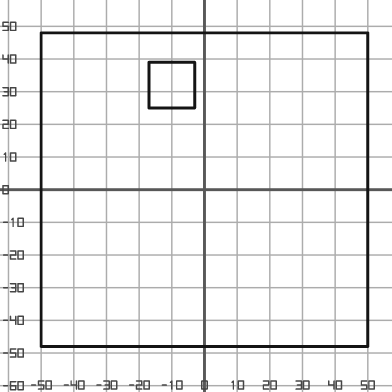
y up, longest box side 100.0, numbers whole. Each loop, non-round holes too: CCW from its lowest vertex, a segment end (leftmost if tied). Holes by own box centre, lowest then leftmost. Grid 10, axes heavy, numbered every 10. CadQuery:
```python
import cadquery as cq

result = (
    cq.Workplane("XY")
    .moveTo(-50.0, -48.0)
    .lineTo(50.0, -48.0)
    .lineTo(50.0, 48.0)
    .lineTo(-50.0, 48.0)
    .close()
    .moveTo(-17.0, 25.0)
    .lineTo(-3.0, 25.0)
    .lineTo(-3.0, 39.0)
    .lineTo(-17.0, 39.0)
    .close()
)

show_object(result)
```